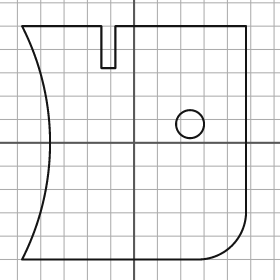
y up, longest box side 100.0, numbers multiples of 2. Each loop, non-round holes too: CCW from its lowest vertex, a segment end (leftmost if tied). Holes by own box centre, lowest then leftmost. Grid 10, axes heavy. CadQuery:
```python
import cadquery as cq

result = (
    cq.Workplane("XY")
    .moveTo(-48.0, -50.0)
    .lineTo(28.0, -50.0)
    .threePointArc((42.0, -44.0), (48.0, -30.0))
    .lineTo(48.0, 50.0)
    .lineTo(-8.0, 50.0)
    .lineTo(-8.0, 32.0)
    .lineTo(-14.0, 32.0)
    .lineTo(-14.0, 50.0)
    .lineTo(-48.0, 50.0)
    .threePointArc((-36.0, 0.0), (-48.0, -50.0))
    .close()
    .moveTo(24.0, 8.0)
    .circle(6.0)
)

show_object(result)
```